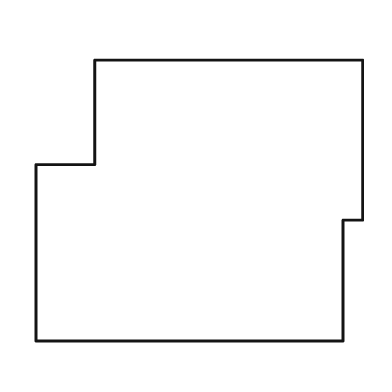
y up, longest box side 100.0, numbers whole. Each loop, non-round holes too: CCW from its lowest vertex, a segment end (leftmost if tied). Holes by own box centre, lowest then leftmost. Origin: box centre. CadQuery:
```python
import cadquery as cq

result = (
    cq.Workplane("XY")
    .moveTo(-50.0, -43.0)
    .lineTo(44.0, -43.0)
    .lineTo(44.0, -6.0)
    .lineTo(50.0, -6.0)
    .lineTo(50.0, 43.0)
    .lineTo(-32.0, 43.0)
    .lineTo(-32.0, 11.0)
    .lineTo(-50.0, 11.0)
    .close()
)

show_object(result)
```